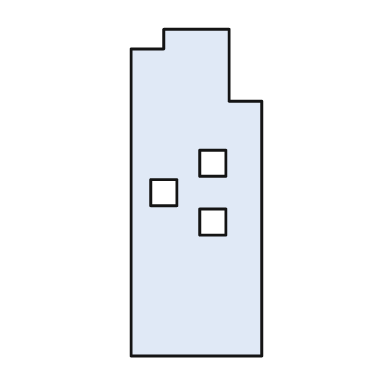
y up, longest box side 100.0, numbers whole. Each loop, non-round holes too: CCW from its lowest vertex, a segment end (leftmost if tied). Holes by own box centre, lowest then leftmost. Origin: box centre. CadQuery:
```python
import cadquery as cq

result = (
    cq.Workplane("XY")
    .moveTo(-20.0, -50.0)
    .lineTo(20.0, -50.0)
    .lineTo(20.0, 28.0)
    .lineTo(10.0, 28.0)
    .lineTo(10.0, 50.0)
    .lineTo(-10.0, 50.0)
    .lineTo(-10.0, 44.0)
    .lineTo(-20.0, 44.0)
    .close()
    .moveTo(1.0, -13.0)
    .lineTo(9.0, -13.0)
    .lineTo(9.0, -5.0)
    .lineTo(1.0, -5.0)
    .close()
    .moveTo(-14.0, -4.0)
    .lineTo(-6.0, -4.0)
    .lineTo(-6.0, 4.0)
    .lineTo(-14.0, 4.0)
    .close()
    .moveTo(1.0, 5.0)
    .lineTo(9.0, 5.0)
    .lineTo(9.0, 13.0)
    .lineTo(1.0, 13.0)
    .close()
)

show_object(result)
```